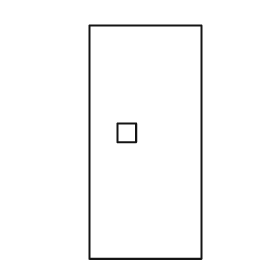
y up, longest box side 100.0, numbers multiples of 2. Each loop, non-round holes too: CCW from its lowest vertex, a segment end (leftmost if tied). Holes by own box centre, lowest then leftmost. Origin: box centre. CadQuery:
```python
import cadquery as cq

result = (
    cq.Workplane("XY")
    .moveTo(-24.0, -50.0)
    .lineTo(24.0, -50.0)
    .lineTo(24.0, 50.0)
    .lineTo(-24.0, 50.0)
    .close()
    .moveTo(-12.0, 0.0)
    .lineTo(-4.0, 0.0)
    .lineTo(-4.0, 8.0)
    .lineTo(-12.0, 8.0)
    .close()
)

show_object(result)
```